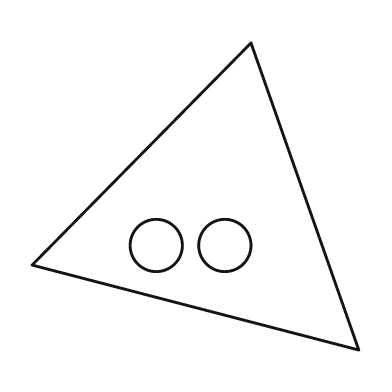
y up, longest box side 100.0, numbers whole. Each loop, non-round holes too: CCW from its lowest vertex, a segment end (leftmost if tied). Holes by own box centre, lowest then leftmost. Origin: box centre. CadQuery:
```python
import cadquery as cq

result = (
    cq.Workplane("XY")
    .moveTo(50.0, -47.0)
    .lineTo(17.0, 47.0)
    .lineTo(-50.0, -21.0)
    .close()
    .moveTo(-12.0, -15.0)
    .circle(8.0)
    .moveTo(9.0, -15.0)
    .circle(8.0)
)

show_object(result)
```